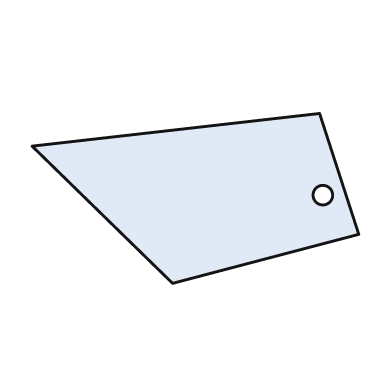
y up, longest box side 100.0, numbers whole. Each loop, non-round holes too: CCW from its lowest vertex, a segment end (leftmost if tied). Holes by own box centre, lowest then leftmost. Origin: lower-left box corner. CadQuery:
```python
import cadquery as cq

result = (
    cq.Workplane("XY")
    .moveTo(43.0, 0.0)
    .lineTo(100.0, 15.0)
    .lineTo(88.0, 52.0)
    .lineTo(0.0, 42.0)
    .close()
    .moveTo(89.0, 27.0)
    .circle(3.0)
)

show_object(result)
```